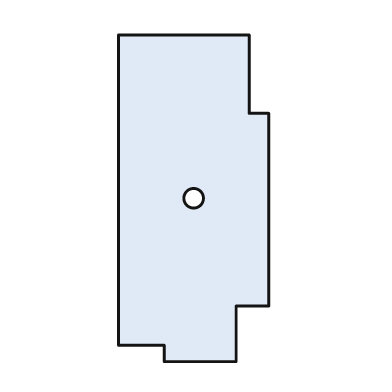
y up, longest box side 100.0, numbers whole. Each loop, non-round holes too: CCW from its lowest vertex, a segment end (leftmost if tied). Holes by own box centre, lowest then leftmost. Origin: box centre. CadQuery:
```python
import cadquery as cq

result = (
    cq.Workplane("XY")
    .moveTo(-9.0, -50.0)
    .lineTo(13.0, -50.0)
    .lineTo(13.0, -33.0)
    .lineTo(23.0, -33.0)
    .lineTo(23.0, 26.0)
    .lineTo(17.0, 26.0)
    .lineTo(17.0, 50.0)
    .lineTo(-23.0, 50.0)
    .lineTo(-23.0, -45.0)
    .lineTo(-9.0, -45.0)
    .close()
    .moveTo(0.0, 0.0)
    .circle(3.0)
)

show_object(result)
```